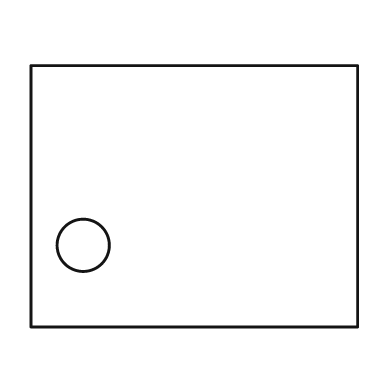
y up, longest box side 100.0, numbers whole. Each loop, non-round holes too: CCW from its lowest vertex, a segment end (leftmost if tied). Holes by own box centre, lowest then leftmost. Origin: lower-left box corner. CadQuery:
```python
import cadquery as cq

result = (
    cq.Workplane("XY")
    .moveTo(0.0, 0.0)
    .lineTo(100.0, 0.0)
    .lineTo(100.0, 80.0)
    .lineTo(0.0, 80.0)
    .close()
    .moveTo(16.0, 25.0)
    .circle(8.0)
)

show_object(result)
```